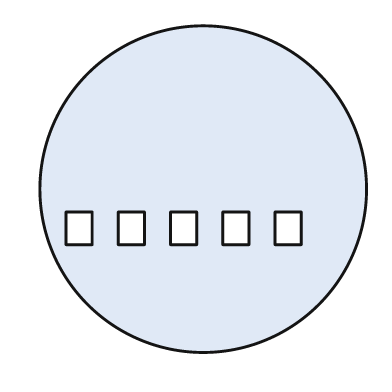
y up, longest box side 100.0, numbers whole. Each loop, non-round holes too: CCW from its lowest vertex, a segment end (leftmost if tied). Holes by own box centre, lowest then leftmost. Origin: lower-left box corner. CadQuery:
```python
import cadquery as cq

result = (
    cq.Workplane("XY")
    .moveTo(50.0, 50.0)
    .circle(50.0)
    .moveTo(8.0, 33.0)
    .lineTo(16.0, 33.0)
    .lineTo(16.0, 43.0)
    .lineTo(8.0, 43.0)
    .close()
    .moveTo(24.0, 33.0)
    .lineTo(32.0, 33.0)
    .lineTo(32.0, 43.0)
    .lineTo(24.0, 43.0)
    .close()
    .moveTo(40.0, 33.0)
    .lineTo(48.0, 33.0)
    .lineTo(48.0, 43.0)
    .lineTo(40.0, 43.0)
    .close()
    .moveTo(56.0, 33.0)
    .lineTo(64.0, 33.0)
    .lineTo(64.0, 43.0)
    .lineTo(56.0, 43.0)
    .close()
    .moveTo(72.0, 33.0)
    .lineTo(80.0, 33.0)
    .lineTo(80.0, 43.0)
    .lineTo(72.0, 43.0)
    .close()
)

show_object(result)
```